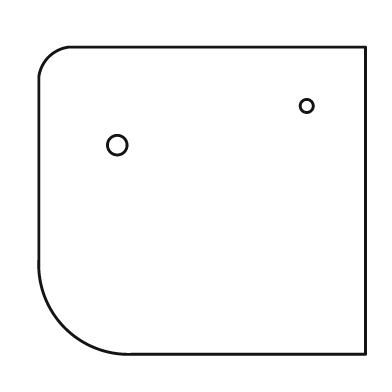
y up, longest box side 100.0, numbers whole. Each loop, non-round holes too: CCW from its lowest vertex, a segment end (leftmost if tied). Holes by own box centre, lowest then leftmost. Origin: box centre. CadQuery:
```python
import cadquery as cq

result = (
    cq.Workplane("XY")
    .moveTo(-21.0, -47.0)
    .lineTo(50.0, -47.0)
    .lineTo(50.0, 47.0)
    .lineTo(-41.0, 47.0)
    .threePointArc((-47.0, 44.0), (-50.0, 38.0))
    .lineTo(-50.0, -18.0)
    .threePointArc((-42.0, -39.0), (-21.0, -47.0))
    .close()
    .moveTo(-26.0, 17.0)
    .circle(3.0)
    .moveTo(32.0, 29.0)
    .circle(2.0)
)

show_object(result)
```